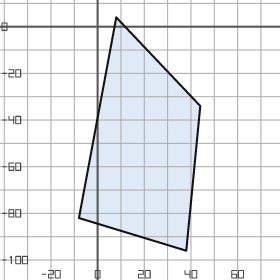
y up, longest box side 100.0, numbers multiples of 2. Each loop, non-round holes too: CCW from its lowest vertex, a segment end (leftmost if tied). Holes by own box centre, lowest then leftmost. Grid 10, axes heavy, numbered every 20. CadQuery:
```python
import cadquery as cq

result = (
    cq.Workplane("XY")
    .moveTo(38.0, -96.0)
    .lineTo(44.0, -34.0)
    .lineTo(8.0, 4.0)
    .lineTo(-8.0, -82.0)
    .close()
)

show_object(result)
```